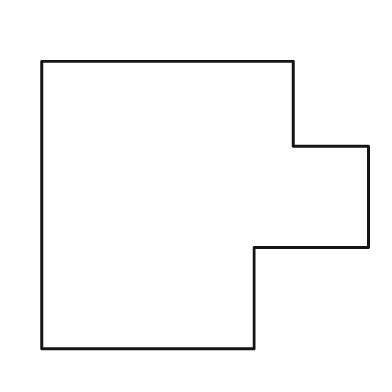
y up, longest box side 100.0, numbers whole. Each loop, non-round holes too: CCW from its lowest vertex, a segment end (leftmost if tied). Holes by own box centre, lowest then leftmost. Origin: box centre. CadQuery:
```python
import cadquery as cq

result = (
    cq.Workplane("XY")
    .moveTo(-50.0, -44.0)
    .lineTo(15.0, -44.0)
    .lineTo(15.0, -13.0)
    .lineTo(50.0, -13.0)
    .lineTo(50.0, 18.0)
    .lineTo(27.0, 18.0)
    .lineTo(27.0, 44.0)
    .lineTo(-50.0, 44.0)
    .close()
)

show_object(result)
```